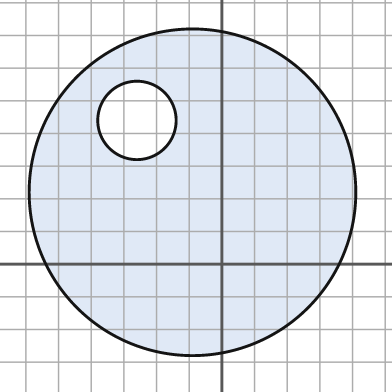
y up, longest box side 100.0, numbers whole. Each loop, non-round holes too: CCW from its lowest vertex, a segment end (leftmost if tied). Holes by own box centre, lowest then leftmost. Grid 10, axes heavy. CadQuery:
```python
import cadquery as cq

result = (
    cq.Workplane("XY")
    .moveTo(-9.0, 22.0)
    .circle(50.0)
    .moveTo(-26.0, 44.0)
    .circle(12.0)
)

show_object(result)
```